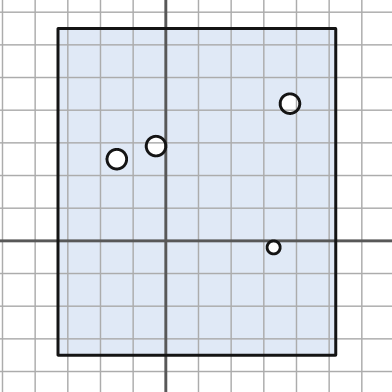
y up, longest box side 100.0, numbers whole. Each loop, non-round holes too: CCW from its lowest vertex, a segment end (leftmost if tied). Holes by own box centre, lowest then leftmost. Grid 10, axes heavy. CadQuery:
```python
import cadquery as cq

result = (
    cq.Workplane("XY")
    .moveTo(-33.0, -35.0)
    .lineTo(52.0, -35.0)
    .lineTo(52.0, 65.0)
    .lineTo(-33.0, 65.0)
    .close()
    .moveTo(33.0, -2.0)
    .circle(2.0)
    .moveTo(-15.0, 25.0)
    .circle(3.0)
    .moveTo(-3.0, 29.0)
    .circle(3.0)
    .moveTo(38.0, 42.0)
    .circle(3.0)
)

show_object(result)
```